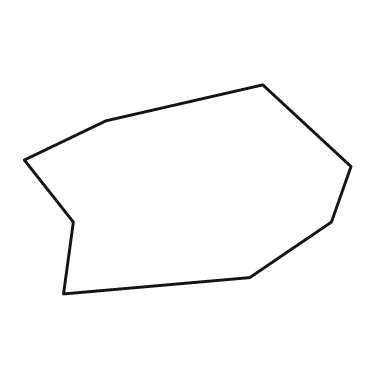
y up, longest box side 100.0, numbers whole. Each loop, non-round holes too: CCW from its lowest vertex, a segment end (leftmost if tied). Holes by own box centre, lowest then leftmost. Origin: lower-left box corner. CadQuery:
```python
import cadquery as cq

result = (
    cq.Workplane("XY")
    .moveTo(12.0, 0.0)
    .lineTo(69.0, 5.0)
    .lineTo(94.0, 22.0)
    .lineTo(100.0, 39.0)
    .lineTo(73.0, 64.0)
    .lineTo(25.0, 53.0)
    .lineTo(0.0, 41.0)
    .lineTo(15.0, 22.0)
    .close()
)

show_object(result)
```